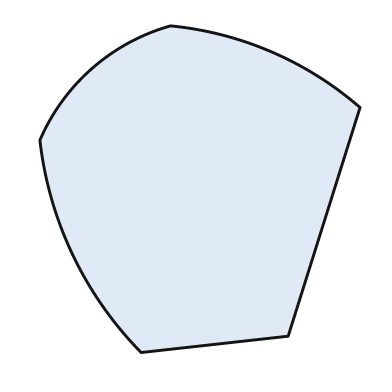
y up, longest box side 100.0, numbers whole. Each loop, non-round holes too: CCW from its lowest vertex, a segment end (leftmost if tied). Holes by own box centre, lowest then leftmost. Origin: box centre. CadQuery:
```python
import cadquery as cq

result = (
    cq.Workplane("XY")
    .moveTo(-18.0, -50.0)
    .lineTo(27.0, -45.0)
    .lineTo(49.0, 25.0)
    .threePointArc((22.0, 42.0), (-9.0, 50.0))
    .threePointArc((-33.0, 37.0), (-49.0, 15.0))
    .threePointArc((-39.0, -20.0), (-18.0, -50.0))
    .close()
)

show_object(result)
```